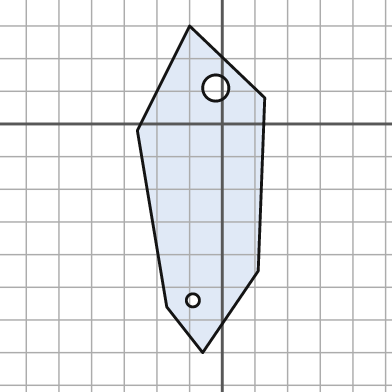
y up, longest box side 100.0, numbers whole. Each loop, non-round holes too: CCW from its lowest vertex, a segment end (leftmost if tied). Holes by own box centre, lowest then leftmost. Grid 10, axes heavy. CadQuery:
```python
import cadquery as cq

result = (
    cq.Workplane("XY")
    .moveTo(-6.0, -70.0)
    .lineTo(11.0, -45.0)
    .lineTo(13.0, 8.0)
    .lineTo(-10.0, 30.0)
    .lineTo(-26.0, -2.0)
    .lineTo(-17.0, -56.0)
    .close()
    .moveTo(-9.0, -54.0)
    .circle(2.0)
    .moveTo(-2.0, 11.0)
    .circle(4.0)
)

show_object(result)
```